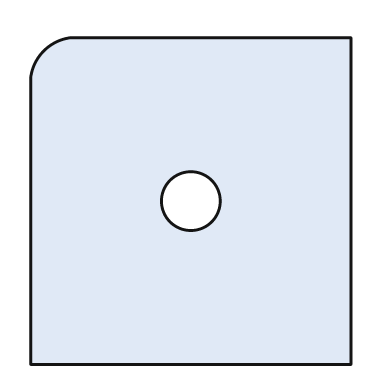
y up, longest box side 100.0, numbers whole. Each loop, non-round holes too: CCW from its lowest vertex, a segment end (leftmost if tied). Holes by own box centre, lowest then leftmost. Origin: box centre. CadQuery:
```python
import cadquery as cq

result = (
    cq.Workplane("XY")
    .moveTo(-49.0, -50.0)
    .lineTo(49.0, -50.0)
    .lineTo(49.0, 50.0)
    .lineTo(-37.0, 50.0)
    .threePointArc((-45.0, 46.0), (-49.0, 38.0))
    .close()
    .moveTo(0.0, 0.0)
    .circle(9.0)
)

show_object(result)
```